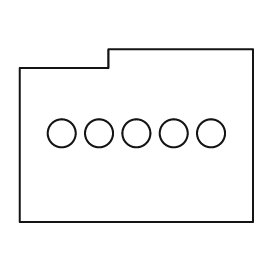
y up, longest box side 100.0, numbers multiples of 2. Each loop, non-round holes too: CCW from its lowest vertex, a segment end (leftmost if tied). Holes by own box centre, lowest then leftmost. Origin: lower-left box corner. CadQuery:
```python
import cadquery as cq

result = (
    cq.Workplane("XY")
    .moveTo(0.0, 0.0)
    .lineTo(100.0, 0.0)
    .lineTo(100.0, 74.0)
    .lineTo(38.0, 74.0)
    .lineTo(38.0, 66.0)
    .lineTo(0.0, 66.0)
    .close()
    .moveTo(18.0, 38.0)
    .circle(6.0)
    .moveTo(34.0, 38.0)
    .circle(6.0)
    .moveTo(50.0, 38.0)
    .circle(6.0)
    .moveTo(66.0, 38.0)
    .circle(6.0)
    .moveTo(82.0, 38.0)
    .circle(6.0)
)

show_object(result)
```